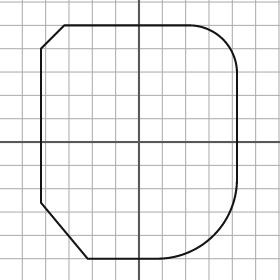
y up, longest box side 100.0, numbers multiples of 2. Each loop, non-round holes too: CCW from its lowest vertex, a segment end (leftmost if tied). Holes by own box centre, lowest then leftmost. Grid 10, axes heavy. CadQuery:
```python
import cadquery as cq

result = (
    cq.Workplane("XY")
    .moveTo(-22.0, -50.0)
    .lineTo(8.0, -50.0)
    .threePointArc((32.0, -40.0), (42.0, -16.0))
    .lineTo(42.0, 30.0)
    .threePointArc((36.0, 44.0), (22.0, 50.0))
    .lineTo(-32.0, 50.0)
    .lineTo(-42.0, 40.0)
    .lineTo(-42.0, -26.0)
    .close()
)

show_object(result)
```